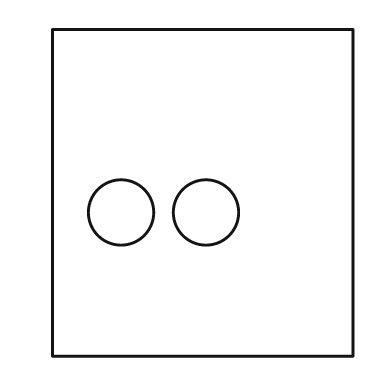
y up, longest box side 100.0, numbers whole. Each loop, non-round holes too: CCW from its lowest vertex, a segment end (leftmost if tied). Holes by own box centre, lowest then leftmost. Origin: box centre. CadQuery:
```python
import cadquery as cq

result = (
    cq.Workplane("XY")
    .moveTo(-46.0, -50.0)
    .lineTo(46.0, -50.0)
    .lineTo(46.0, 50.0)
    .lineTo(-46.0, 50.0)
    .close()
    .moveTo(-25.0, -6.0)
    .circle(10.0)
    .moveTo(1.0, -6.0)
    .circle(10.0)
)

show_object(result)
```